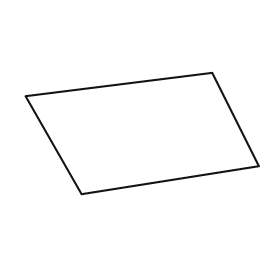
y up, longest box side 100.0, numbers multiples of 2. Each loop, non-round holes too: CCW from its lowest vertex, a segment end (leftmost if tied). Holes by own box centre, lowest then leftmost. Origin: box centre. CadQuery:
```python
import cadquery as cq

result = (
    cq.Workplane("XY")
    .moveTo(-26.0, -26.0)
    .lineTo(50.0, -14.0)
    .lineTo(30.0, 26.0)
    .lineTo(-50.0, 16.0)
    .close()
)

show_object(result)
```